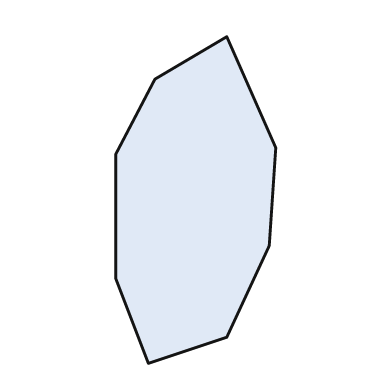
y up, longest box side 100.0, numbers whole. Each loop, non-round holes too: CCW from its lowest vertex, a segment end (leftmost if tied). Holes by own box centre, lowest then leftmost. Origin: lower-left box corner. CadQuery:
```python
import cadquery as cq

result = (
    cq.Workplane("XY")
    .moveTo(10.0, 0.0)
    .lineTo(34.0, 8.0)
    .lineTo(47.0, 36.0)
    .lineTo(49.0, 66.0)
    .lineTo(34.0, 100.0)
    .lineTo(12.0, 87.0)
    .lineTo(0.0, 64.0)
    .lineTo(0.0, 26.0)
    .close()
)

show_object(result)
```